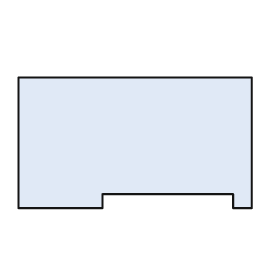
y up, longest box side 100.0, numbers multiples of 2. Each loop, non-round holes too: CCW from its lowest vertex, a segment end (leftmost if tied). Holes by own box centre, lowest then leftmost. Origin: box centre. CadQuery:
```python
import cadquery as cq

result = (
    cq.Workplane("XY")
    .moveTo(-50.0, -28.0)
    .lineTo(-14.0, -28.0)
    .lineTo(-14.0, -22.0)
    .lineTo(42.0, -22.0)
    .lineTo(42.0, -28.0)
    .lineTo(50.0, -28.0)
    .lineTo(50.0, 28.0)
    .lineTo(-50.0, 28.0)
    .close()
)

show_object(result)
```